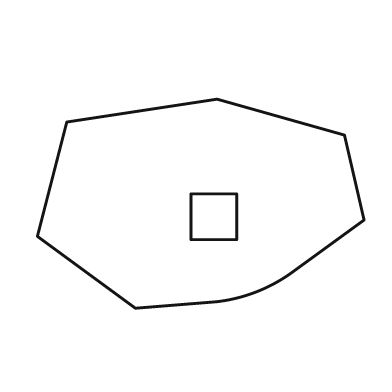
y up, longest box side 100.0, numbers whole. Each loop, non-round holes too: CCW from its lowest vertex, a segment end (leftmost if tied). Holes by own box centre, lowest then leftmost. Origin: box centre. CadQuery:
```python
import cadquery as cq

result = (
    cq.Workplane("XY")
    .moveTo(-20.0, -32.0)
    .lineTo(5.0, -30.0)
    .threePointArc((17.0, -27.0), (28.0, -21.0))
    .lineTo(50.0, -5.0)
    .lineTo(44.0, 21.0)
    .lineTo(5.0, 32.0)
    .lineTo(-41.0, 25.0)
    .lineTo(-50.0, -10.0)
    .close()
    .moveTo(-3.0, -11.0)
    .lineTo(11.0, -11.0)
    .lineTo(11.0, 3.0)
    .lineTo(-3.0, 3.0)
    .close()
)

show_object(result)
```